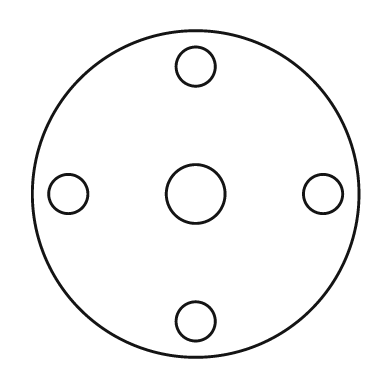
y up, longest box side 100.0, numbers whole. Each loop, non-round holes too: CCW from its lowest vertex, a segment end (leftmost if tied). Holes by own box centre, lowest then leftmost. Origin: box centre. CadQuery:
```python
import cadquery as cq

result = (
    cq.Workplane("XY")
    .moveTo(0.0, 0.0)
    .circle(50.0)
    .moveTo(0.0, -39.0)
    .circle(6.0)
    .moveTo(-39.0, 0.0)
    .circle(6.0)
    .moveTo(0.0, 0.0)
    .circle(9.0)
    .moveTo(39.0, 0.0)
    .circle(6.0)
    .moveTo(0.0, 39.0)
    .circle(6.0)
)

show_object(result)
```